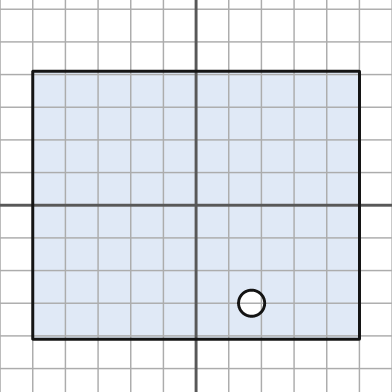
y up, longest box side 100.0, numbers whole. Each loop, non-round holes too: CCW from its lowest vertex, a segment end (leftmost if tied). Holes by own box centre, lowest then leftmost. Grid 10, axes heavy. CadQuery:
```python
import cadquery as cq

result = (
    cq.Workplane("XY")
    .moveTo(-50.0, -41.0)
    .lineTo(50.0, -41.0)
    .lineTo(50.0, 41.0)
    .lineTo(-50.0, 41.0)
    .close()
    .moveTo(17.0, -30.0)
    .circle(4.0)
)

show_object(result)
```